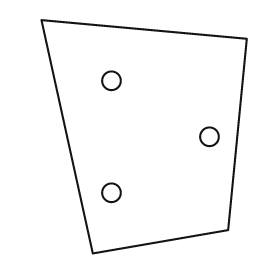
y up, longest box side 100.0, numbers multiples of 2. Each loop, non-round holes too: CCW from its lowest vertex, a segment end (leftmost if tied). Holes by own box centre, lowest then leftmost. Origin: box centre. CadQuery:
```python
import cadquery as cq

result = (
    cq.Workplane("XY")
    .moveTo(-22.0, -50.0)
    .lineTo(36.0, -40.0)
    .lineTo(44.0, 42.0)
    .lineTo(-44.0, 50.0)
    .close()
    .moveTo(-14.0, -24.0)
    .circle(4.0)
    .moveTo(28.0, 0.0)
    .circle(4.0)
    .moveTo(-14.0, 24.0)
    .circle(4.0)
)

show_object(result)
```